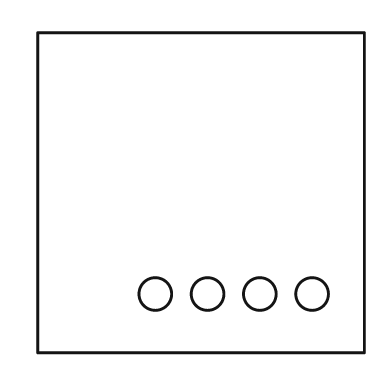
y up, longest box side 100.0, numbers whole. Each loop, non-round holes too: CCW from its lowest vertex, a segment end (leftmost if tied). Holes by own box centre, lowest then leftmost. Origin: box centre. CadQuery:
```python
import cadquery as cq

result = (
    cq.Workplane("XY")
    .moveTo(-50.0, -49.0)
    .lineTo(50.0, -49.0)
    .lineTo(50.0, 49.0)
    .lineTo(-50.0, 49.0)
    .close()
    .moveTo(-14.0, -31.0)
    .circle(5.0)
    .moveTo(2.0, -31.0)
    .circle(5.0)
    .moveTo(18.0, -31.0)
    .circle(5.0)
    .moveTo(34.0, -31.0)
    .circle(5.0)
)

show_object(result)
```